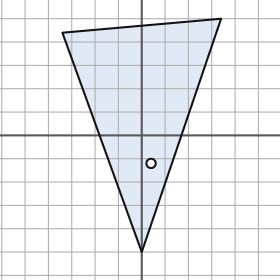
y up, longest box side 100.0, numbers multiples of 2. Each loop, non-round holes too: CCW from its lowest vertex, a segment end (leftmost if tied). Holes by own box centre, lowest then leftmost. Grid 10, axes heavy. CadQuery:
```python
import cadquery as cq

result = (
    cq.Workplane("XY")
    .moveTo(0.0, -50.0)
    .lineTo(34.0, 50.0)
    .lineTo(-34.0, 44.0)
    .close()
    .moveTo(4.0, -12.0)
    .circle(2.0)
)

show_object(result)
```